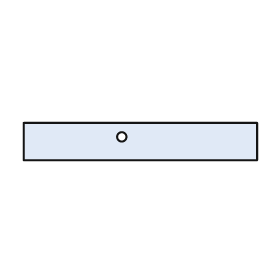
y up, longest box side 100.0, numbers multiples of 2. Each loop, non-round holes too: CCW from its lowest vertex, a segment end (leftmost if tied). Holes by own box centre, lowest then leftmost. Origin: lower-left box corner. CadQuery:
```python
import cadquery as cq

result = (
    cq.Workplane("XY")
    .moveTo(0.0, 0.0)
    .lineTo(100.0, 0.0)
    .lineTo(100.0, 16.0)
    .lineTo(0.0, 16.0)
    .close()
    .moveTo(42.0, 10.0)
    .circle(2.0)
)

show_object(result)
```